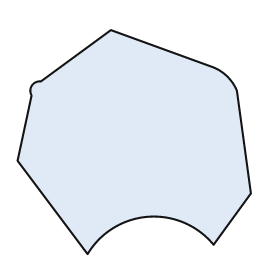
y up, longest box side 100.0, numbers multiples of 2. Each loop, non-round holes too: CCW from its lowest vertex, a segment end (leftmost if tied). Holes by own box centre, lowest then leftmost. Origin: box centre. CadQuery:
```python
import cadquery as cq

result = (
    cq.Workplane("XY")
    .moveTo(-20.0, -48.0)
    .threePointArc((6.0, -32.0), (34.0, -44.0))
    .lineTo(50.0, -22.0)
    .lineTo(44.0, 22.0)
    .threePointArc((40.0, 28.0), (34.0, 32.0))
    .lineTo(-10.0, 48.0)
    .lineTo(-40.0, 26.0)
    .threePointArc((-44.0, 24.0), (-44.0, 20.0))
    .lineTo(-50.0, -8.0)
    .close()
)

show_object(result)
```